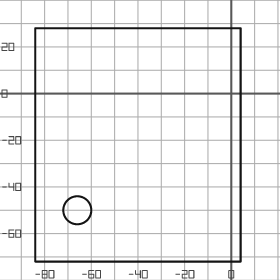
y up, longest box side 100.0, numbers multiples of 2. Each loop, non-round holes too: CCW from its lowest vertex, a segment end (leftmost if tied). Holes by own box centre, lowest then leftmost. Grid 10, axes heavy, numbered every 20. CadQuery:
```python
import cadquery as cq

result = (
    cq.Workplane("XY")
    .moveTo(-84.0, -72.0)
    .lineTo(4.0, -72.0)
    .lineTo(4.0, 28.0)
    .lineTo(-84.0, 28.0)
    .close()
    .moveTo(-66.0, -50.0)
    .circle(6.0)
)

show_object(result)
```